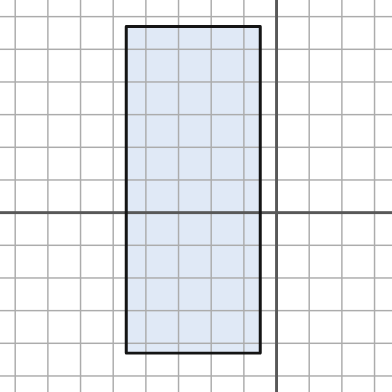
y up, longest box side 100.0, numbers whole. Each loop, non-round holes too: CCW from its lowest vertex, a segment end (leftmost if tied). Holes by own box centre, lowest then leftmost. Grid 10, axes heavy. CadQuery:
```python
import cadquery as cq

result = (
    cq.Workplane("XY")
    .moveTo(-46.0, -43.0)
    .lineTo(-5.0, -43.0)
    .lineTo(-5.0, 57.0)
    .lineTo(-46.0, 57.0)
    .close()
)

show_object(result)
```